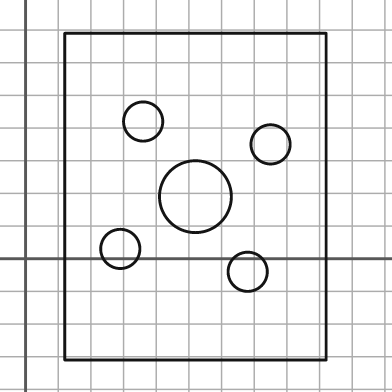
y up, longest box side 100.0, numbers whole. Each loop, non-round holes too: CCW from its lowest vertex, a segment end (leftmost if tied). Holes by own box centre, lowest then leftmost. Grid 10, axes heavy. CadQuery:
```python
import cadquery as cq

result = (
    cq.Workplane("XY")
    .moveTo(12.0, -31.0)
    .lineTo(92.0, -31.0)
    .lineTo(92.0, 69.0)
    .lineTo(12.0, 69.0)
    .close()
    .moveTo(68.0, -4.0)
    .circle(6.0)
    .moveTo(29.0, 3.0)
    .circle(6.0)
    .moveTo(52.0, 19.0)
    .circle(11.0)
    .moveTo(75.0, 35.0)
    .circle(6.0)
    .moveTo(36.0, 42.0)
    .circle(6.0)
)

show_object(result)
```